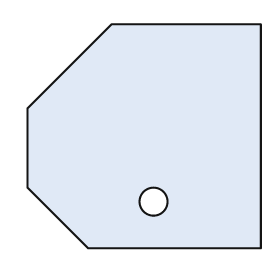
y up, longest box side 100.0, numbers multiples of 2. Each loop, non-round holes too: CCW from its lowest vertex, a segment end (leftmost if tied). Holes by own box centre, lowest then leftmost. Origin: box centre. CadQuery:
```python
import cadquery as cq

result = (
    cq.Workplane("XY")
    .moveTo(-24.0, -48.0)
    .lineTo(50.0, -48.0)
    .lineTo(50.0, 48.0)
    .lineTo(-14.0, 48.0)
    .lineTo(-50.0, 12.0)
    .lineTo(-50.0, -22.0)
    .close()
    .moveTo(4.0, -28.0)
    .circle(6.0)
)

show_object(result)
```